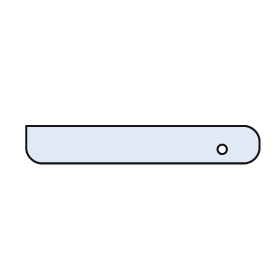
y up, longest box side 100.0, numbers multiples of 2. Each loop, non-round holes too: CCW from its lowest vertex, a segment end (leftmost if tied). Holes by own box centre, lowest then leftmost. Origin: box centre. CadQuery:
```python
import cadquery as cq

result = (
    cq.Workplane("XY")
    .moveTo(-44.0, -8.0)
    .lineTo(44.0, -8.0)
    .threePointArc((48.0, -6.0), (50.0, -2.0))
    .lineTo(50.0, 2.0)
    .threePointArc((48.0, 6.0), (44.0, 8.0))
    .lineTo(-50.0, 8.0)
    .lineTo(-50.0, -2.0)
    .threePointArc((-48.0, -6.0), (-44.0, -8.0))
    .close()
    .moveTo(34.0, -2.0)
    .circle(2.0)
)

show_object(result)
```